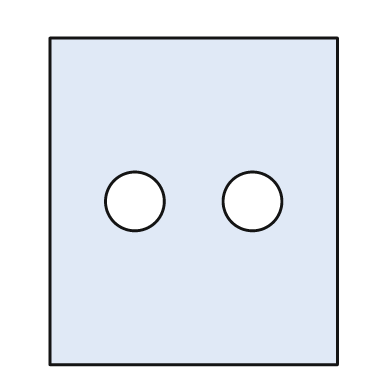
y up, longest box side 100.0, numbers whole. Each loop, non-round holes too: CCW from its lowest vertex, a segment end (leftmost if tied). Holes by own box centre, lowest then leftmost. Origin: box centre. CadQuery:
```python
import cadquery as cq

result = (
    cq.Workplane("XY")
    .moveTo(-44.0, -50.0)
    .lineTo(44.0, -50.0)
    .lineTo(44.0, 50.0)
    .lineTo(-44.0, 50.0)
    .close()
    .moveTo(-18.0, 0.0)
    .circle(9.0)
    .moveTo(18.0, 0.0)
    .circle(9.0)
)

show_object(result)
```